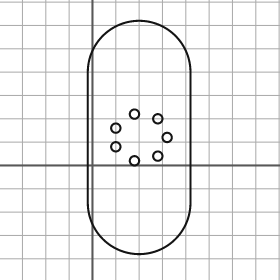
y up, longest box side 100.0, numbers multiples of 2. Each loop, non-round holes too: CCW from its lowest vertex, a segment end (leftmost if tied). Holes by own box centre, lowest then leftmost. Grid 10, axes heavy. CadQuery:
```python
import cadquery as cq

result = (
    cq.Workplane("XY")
    .moveTo(-2.0, -16.0)
    .threePointArc((20.0, -38.0), (42.0, -16.0))
    .lineTo(42.0, 40.0)
    .threePointArc((20.0, 62.0), (-2.0, 40.0))
    .close()
    .moveTo(18.0, 2.0)
    .circle(2.0)
    .moveTo(28.0, 4.0)
    .circle(2.0)
    .moveTo(10.0, 8.0)
    .circle(2.0)
    .moveTo(32.0, 12.0)
    .circle(2.0)
    .moveTo(10.0, 16.0)
    .circle(2.0)
    .moveTo(28.0, 20.0)
    .circle(2.0)
    .moveTo(18.0, 22.0)
    .circle(2.0)
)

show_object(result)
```